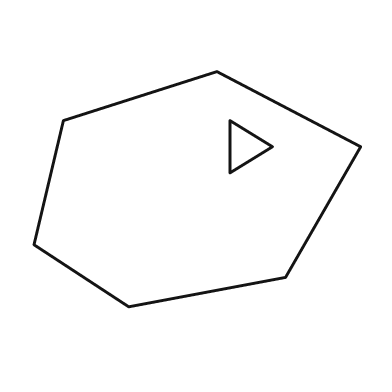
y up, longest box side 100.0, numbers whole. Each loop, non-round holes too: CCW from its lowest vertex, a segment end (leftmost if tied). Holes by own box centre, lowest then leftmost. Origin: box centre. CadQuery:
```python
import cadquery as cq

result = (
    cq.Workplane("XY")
    .moveTo(-21.0, -36.0)
    .lineTo(27.0, -27.0)
    .lineTo(50.0, 13.0)
    .lineTo(6.0, 36.0)
    .lineTo(-41.0, 21.0)
    .lineTo(-50.0, -17.0)
    .close()
    .moveTo(10.0, 5.0)
    .lineTo(23.0, 13.0)
    .lineTo(10.0, 21.0)
    .close()
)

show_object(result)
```